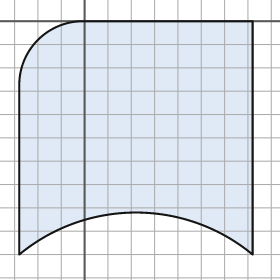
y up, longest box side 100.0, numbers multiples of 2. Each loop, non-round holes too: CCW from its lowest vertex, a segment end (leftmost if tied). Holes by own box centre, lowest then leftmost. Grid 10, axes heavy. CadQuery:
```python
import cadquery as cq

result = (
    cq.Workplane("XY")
    .moveTo(-28.0, -100.0)
    .threePointArc((22.0, -82.0), (72.0, -100.0))
    .lineTo(72.0, 0.0)
    .lineTo(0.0, 0.0)
    .threePointArc((-20.0, -8.0), (-28.0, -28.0))
    .close()
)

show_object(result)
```